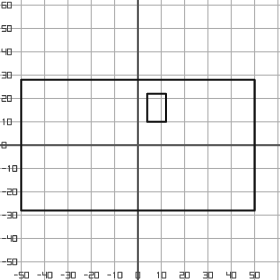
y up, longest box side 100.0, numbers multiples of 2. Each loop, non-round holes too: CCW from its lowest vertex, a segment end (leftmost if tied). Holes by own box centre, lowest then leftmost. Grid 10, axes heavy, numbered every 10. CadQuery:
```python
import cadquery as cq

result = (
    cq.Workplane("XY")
    .moveTo(-50.0, -28.0)
    .lineTo(50.0, -28.0)
    .lineTo(50.0, 28.0)
    .lineTo(-50.0, 28.0)
    .close()
    .moveTo(4.0, 10.0)
    .lineTo(12.0, 10.0)
    .lineTo(12.0, 22.0)
    .lineTo(4.0, 22.0)
    .close()
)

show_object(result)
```